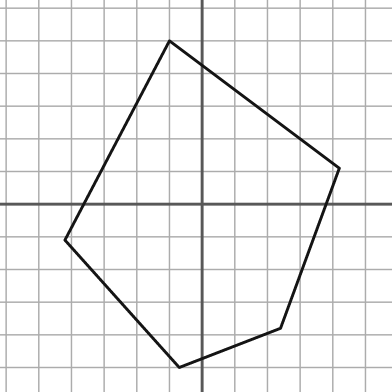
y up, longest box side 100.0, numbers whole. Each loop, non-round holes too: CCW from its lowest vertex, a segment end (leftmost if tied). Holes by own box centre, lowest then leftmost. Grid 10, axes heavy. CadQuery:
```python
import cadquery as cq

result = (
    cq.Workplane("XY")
    .moveTo(-7.0, -50.0)
    .lineTo(24.0, -38.0)
    .lineTo(42.0, 11.0)
    .lineTo(-10.0, 50.0)
    .lineTo(-42.0, -11.0)
    .close()
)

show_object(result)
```